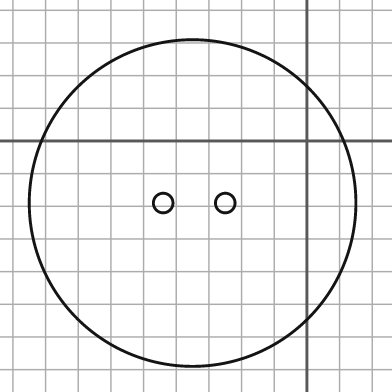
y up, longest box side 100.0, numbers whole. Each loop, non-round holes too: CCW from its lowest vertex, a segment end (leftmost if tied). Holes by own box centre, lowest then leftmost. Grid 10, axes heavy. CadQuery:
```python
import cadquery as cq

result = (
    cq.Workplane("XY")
    .moveTo(-35.0, -19.0)
    .circle(50.0)
    .moveTo(-44.0, -19.0)
    .circle(3.0)
    .moveTo(-25.0, -19.0)
    .circle(3.0)
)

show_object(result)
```